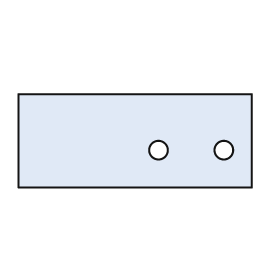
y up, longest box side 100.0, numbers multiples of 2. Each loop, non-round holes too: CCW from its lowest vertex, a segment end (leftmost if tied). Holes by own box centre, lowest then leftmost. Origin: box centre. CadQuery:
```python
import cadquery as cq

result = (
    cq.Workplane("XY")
    .moveTo(-50.0, -20.0)
    .lineTo(50.0, -20.0)
    .lineTo(50.0, 20.0)
    .lineTo(-50.0, 20.0)
    .close()
    .moveTo(10.0, -4.0)
    .circle(4.0)
    .moveTo(38.0, -4.0)
    .circle(4.0)
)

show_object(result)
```